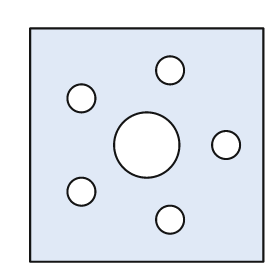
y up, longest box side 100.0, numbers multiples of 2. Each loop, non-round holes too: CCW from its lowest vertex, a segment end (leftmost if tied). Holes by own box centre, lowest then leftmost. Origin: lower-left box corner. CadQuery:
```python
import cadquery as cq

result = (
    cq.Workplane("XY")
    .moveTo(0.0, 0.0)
    .lineTo(100.0, 0.0)
    .lineTo(100.0, 100.0)
    .lineTo(0.0, 100.0)
    .close()
    .moveTo(60.0, 18.0)
    .circle(6.0)
    .moveTo(22.0, 30.0)
    .circle(6.0)
    .moveTo(50.0, 50.0)
    .circle(14.0)
    .moveTo(84.0, 50.0)
    .circle(6.0)
    .moveTo(22.0, 70.0)
    .circle(6.0)
    .moveTo(60.0, 82.0)
    .circle(6.0)
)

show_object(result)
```